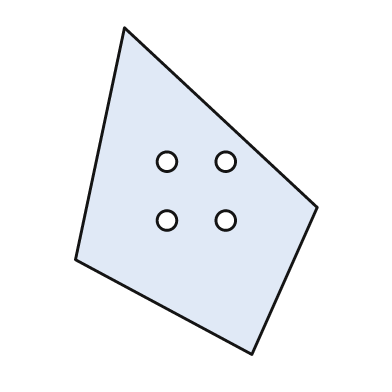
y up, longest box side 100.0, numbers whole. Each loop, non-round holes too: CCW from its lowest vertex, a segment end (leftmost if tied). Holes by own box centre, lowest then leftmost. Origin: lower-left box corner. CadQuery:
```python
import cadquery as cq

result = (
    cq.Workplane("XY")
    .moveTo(54.0, 0.0)
    .lineTo(74.0, 45.0)
    .lineTo(15.0, 100.0)
    .lineTo(0.0, 29.0)
    .close()
    .moveTo(28.0, 41.0)
    .circle(3.0)
    .moveTo(46.0, 41.0)
    .circle(3.0)
    .moveTo(28.0, 59.0)
    .circle(3.0)
    .moveTo(46.0, 59.0)
    .circle(3.0)
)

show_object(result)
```